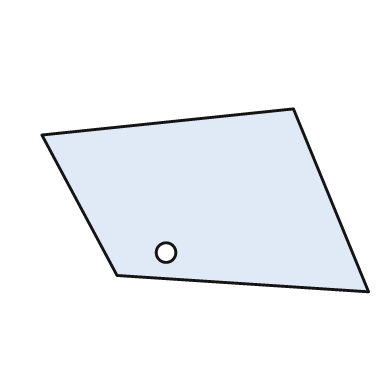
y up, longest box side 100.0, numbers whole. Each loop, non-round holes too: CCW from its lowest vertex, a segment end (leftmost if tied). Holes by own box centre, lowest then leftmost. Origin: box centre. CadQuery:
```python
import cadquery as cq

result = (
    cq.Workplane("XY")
    .moveTo(50.0, -28.0)
    .lineTo(27.0, 28.0)
    .lineTo(-50.0, 20.0)
    .lineTo(-27.0, -23.0)
    .close()
    .moveTo(-12.0, -16.0)
    .circle(3.0)
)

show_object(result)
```